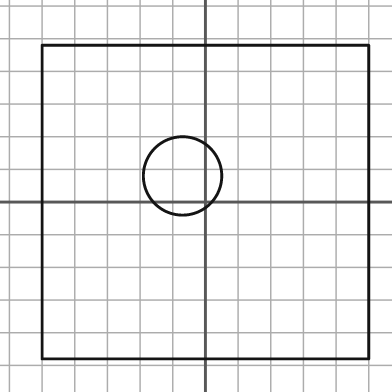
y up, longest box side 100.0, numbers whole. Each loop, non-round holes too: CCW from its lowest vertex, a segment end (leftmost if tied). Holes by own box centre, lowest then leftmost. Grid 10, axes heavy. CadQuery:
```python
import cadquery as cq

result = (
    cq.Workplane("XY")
    .moveTo(-50.0, -48.0)
    .lineTo(50.0, -48.0)
    .lineTo(50.0, 48.0)
    .lineTo(-50.0, 48.0)
    .close()
    .moveTo(-7.0, 8.0)
    .circle(12.0)
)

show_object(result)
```